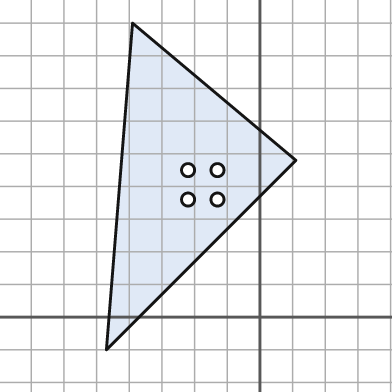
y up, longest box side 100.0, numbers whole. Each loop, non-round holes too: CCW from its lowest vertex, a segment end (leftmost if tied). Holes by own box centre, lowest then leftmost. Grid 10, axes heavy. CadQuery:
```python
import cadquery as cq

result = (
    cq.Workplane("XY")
    .moveTo(-47.0, -10.0)
    .lineTo(11.0, 48.0)
    .lineTo(-39.0, 90.0)
    .close()
    .moveTo(-22.0, 36.0)
    .circle(2.0)
    .moveTo(-13.0, 36.0)
    .circle(2.0)
    .moveTo(-22.0, 45.0)
    .circle(2.0)
    .moveTo(-13.0, 45.0)
    .circle(2.0)
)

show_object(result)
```